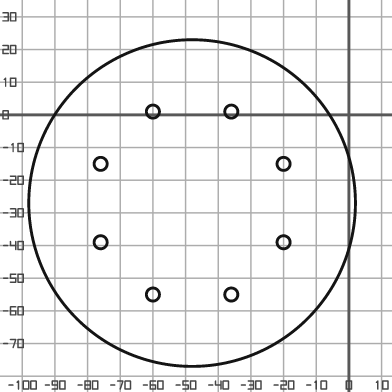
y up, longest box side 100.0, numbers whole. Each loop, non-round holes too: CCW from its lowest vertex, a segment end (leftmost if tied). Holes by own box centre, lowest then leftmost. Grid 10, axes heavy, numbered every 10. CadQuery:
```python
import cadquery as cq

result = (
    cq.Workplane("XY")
    .moveTo(-48.0, -27.0)
    .circle(50.0)
    .moveTo(-60.0, -55.0)
    .circle(2.0)
    .moveTo(-36.0, -55.0)
    .circle(2.0)
    .moveTo(-76.0, -39.0)
    .circle(2.0)
    .moveTo(-20.0, -39.0)
    .circle(2.0)
    .moveTo(-76.0, -15.0)
    .circle(2.0)
    .moveTo(-20.0, -15.0)
    .circle(2.0)
    .moveTo(-60.0, 1.0)
    .circle(2.0)
    .moveTo(-36.0, 1.0)
    .circle(2.0)
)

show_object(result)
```